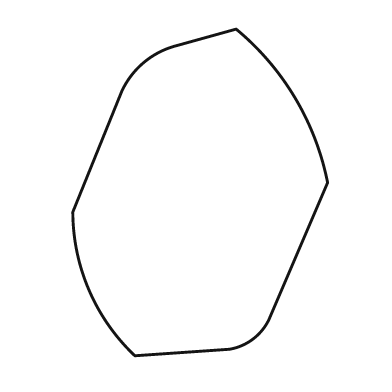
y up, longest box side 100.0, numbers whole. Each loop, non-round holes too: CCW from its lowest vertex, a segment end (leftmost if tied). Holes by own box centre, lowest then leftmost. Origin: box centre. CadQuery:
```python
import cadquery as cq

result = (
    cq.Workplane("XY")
    .moveTo(-20.0, -50.0)
    .lineTo(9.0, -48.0)
    .threePointArc((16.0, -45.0), (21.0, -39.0))
    .lineTo(39.0, 3.0)
    .threePointArc((29.0, 29.0), (11.0, 50.0))
    .lineTo(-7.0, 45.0)
    .threePointArc((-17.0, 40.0), (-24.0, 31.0))
    .lineTo(-39.0, -6.0)
    .threePointArc((-34.0, -30.0), (-20.0, -50.0))
    .close()
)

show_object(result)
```